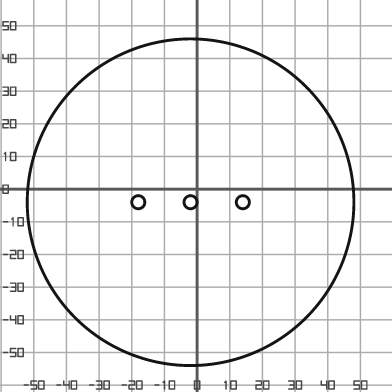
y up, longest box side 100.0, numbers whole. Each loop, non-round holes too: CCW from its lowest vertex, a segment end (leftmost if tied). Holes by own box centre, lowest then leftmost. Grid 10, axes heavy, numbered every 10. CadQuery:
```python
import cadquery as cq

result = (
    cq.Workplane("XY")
    .moveTo(-2.0, -4.0)
    .circle(50.0)
    .moveTo(-18.0, -4.0)
    .circle(2.0)
    .moveTo(-2.0, -4.0)
    .circle(2.0)
    .moveTo(14.0, -4.0)
    .circle(2.0)
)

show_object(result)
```